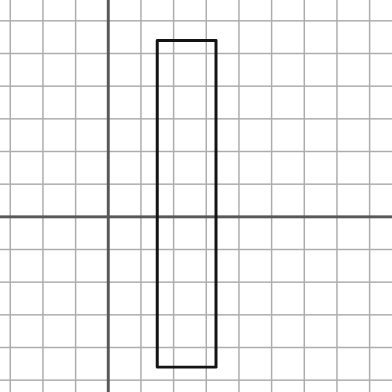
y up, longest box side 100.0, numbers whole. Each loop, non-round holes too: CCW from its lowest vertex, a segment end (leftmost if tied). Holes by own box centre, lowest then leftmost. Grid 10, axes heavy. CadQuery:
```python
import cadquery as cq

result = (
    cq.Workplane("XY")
    .moveTo(15.0, -46.0)
    .lineTo(33.0, -46.0)
    .lineTo(33.0, 54.0)
    .lineTo(15.0, 54.0)
    .close()
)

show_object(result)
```